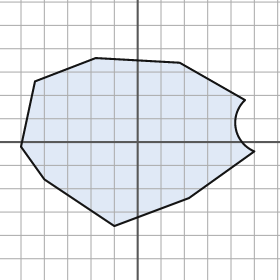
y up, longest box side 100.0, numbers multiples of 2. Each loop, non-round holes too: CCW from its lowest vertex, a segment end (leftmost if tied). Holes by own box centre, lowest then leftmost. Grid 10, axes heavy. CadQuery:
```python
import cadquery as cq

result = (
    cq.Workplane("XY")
    .moveTo(-10.0, -36.0)
    .lineTo(22.0, -24.0)
    .lineTo(50.0, -4.0)
    .threePointArc((42.0, 6.0), (46.0, 18.0))
    .lineTo(18.0, 34.0)
    .lineTo(-18.0, 36.0)
    .lineTo(-44.0, 26.0)
    .lineTo(-50.0, -2.0)
    .lineTo(-40.0, -16.0)
    .close()
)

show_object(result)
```